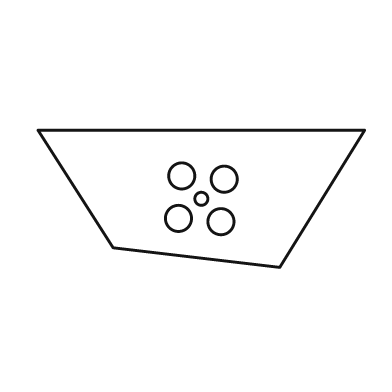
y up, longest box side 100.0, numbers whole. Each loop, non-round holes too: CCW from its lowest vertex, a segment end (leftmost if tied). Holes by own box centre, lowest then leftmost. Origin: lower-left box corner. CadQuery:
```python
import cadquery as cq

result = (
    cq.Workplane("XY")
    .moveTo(74.0, 0.0)
    .lineTo(100.0, 42.0)
    .lineTo(0.0, 42.0)
    .lineTo(23.0, 6.0)
    .close()
    .moveTo(56.0, 14.0)
    .circle(4.0)
    .moveTo(43.0, 15.0)
    .circle(4.0)
    .moveTo(50.0, 21.0)
    .circle(2.0)
    .moveTo(57.0, 27.0)
    .circle(4.0)
    .moveTo(44.0, 28.0)
    .circle(4.0)
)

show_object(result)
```